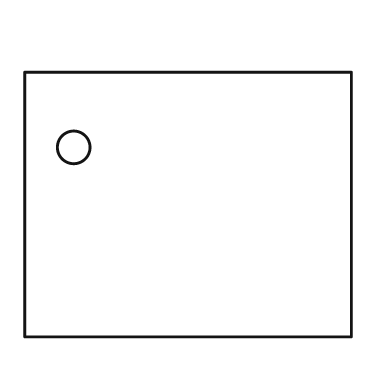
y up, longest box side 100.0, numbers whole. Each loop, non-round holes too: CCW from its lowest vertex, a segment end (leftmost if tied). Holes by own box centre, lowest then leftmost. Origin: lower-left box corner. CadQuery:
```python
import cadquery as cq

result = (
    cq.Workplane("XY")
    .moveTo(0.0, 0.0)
    .lineTo(100.0, 0.0)
    .lineTo(100.0, 81.0)
    .lineTo(0.0, 81.0)
    .close()
    .moveTo(15.0, 58.0)
    .circle(5.0)
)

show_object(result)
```